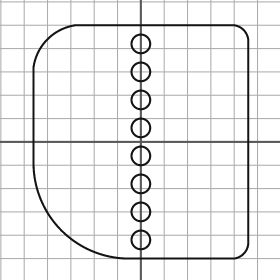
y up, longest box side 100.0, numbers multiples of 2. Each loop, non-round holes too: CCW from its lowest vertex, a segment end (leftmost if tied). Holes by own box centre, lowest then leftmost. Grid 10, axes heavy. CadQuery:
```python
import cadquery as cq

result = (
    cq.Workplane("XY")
    .moveTo(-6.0, -50.0)
    .lineTo(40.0, -50.0)
    .threePointArc((44.0, -48.0), (46.0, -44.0))
    .lineTo(46.0, 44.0)
    .threePointArc((44.0, 48.0), (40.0, 50.0))
    .lineTo(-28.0, 50.0)
    .threePointArc((-40.0, 44.0), (-46.0, 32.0))
    .lineTo(-46.0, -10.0)
    .threePointArc((-34.0, -38.0), (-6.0, -50.0))
    .close()
    .moveTo(0.0, -42.0)
    .circle(4.0)
    .moveTo(0.0, -30.0)
    .circle(4.0)
    .moveTo(0.0, -18.0)
    .circle(4.0)
    .moveTo(0.0, -6.0)
    .circle(4.0)
    .moveTo(0.0, 6.0)
    .circle(4.0)
    .moveTo(0.0, 18.0)
    .circle(4.0)
    .moveTo(0.0, 30.0)
    .circle(4.0)
    .moveTo(0.0, 42.0)
    .circle(4.0)
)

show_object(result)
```